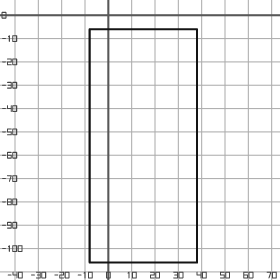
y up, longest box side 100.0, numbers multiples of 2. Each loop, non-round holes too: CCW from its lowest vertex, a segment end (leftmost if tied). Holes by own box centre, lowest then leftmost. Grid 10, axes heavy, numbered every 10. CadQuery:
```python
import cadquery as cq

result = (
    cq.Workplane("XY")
    .moveTo(-8.0, -106.0)
    .lineTo(38.0, -106.0)
    .lineTo(38.0, -6.0)
    .lineTo(-8.0, -6.0)
    .close()
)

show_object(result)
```